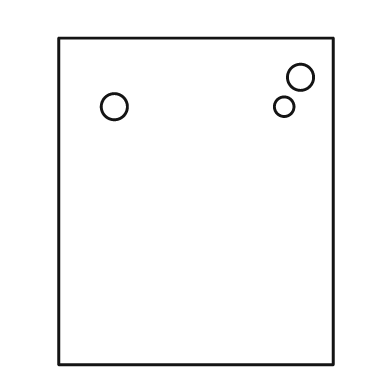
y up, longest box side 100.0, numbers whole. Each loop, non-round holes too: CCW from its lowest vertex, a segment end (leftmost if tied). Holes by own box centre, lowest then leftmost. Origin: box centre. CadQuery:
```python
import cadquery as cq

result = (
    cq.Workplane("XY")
    .moveTo(-42.0, -50.0)
    .lineTo(42.0, -50.0)
    .lineTo(42.0, 50.0)
    .lineTo(-42.0, 50.0)
    .close()
    .moveTo(-25.0, 29.0)
    .circle(4.0)
    .moveTo(27.0, 29.0)
    .circle(3.0)
    .moveTo(32.0, 38.0)
    .circle(4.0)
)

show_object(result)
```